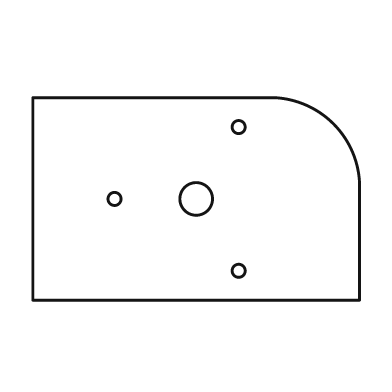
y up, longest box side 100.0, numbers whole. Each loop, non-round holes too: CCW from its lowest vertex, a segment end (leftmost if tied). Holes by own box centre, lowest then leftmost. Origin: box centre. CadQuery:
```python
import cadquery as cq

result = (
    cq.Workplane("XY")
    .moveTo(-50.0, -31.0)
    .lineTo(50.0, -31.0)
    .lineTo(50.0, 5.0)
    .threePointArc((42.0, 23.0), (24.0, 31.0))
    .lineTo(-50.0, 31.0)
    .close()
    .moveTo(13.0, -22.0)
    .circle(2.0)
    .moveTo(-25.0, 0.0)
    .circle(2.0)
    .moveTo(0.0, 0.0)
    .circle(5.0)
    .moveTo(13.0, 22.0)
    .circle(2.0)
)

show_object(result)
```